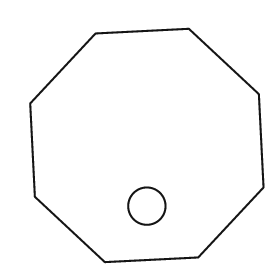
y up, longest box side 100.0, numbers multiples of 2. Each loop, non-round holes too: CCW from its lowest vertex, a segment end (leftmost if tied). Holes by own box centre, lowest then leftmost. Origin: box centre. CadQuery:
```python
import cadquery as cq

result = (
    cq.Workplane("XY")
    .moveTo(-18.0, -50.0)
    .lineTo(22.0, -48.0)
    .lineTo(50.0, -18.0)
    .lineTo(48.0, 22.0)
    .lineTo(18.0, 50.0)
    .lineTo(-22.0, 48.0)
    .lineTo(-50.0, 18.0)
    .lineTo(-48.0, -22.0)
    .close()
    .moveTo(0.0, -26.0)
    .circle(8.0)
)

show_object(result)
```